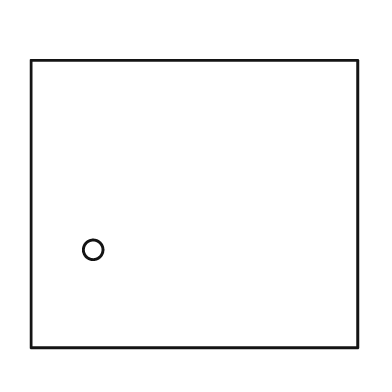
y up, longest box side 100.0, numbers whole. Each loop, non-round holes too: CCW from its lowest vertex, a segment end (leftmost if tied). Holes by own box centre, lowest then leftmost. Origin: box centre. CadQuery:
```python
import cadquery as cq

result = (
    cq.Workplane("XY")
    .moveTo(-50.0, -44.0)
    .lineTo(50.0, -44.0)
    .lineTo(50.0, 44.0)
    .lineTo(-50.0, 44.0)
    .close()
    .moveTo(-31.0, -14.0)
    .circle(3.0)
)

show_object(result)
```